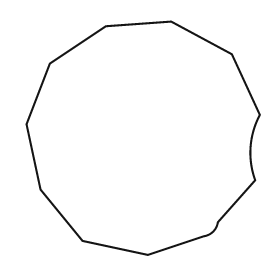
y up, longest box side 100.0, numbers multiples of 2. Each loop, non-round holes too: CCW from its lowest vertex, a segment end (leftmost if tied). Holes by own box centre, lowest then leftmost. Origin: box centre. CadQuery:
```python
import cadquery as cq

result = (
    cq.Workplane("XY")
    .moveTo(2.0, -50.0)
    .lineTo(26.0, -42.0)
    .threePointArc((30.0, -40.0), (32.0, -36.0))
    .lineTo(48.0, -18.0)
    .threePointArc((46.0, -4.0), (50.0, 10.0))
    .lineTo(38.0, 36.0)
    .lineTo(12.0, 50.0)
    .lineTo(-16.0, 48.0)
    .lineTo(-40.0, 32.0)
    .lineTo(-50.0, 6.0)
    .lineTo(-44.0, -22.0)
    .lineTo(-26.0, -44.0)
    .close()
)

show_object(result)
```